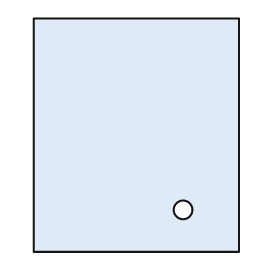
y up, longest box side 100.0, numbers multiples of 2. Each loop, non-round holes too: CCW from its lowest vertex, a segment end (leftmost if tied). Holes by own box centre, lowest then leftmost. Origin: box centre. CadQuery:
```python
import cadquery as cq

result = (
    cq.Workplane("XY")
    .moveTo(-44.0, -50.0)
    .lineTo(44.0, -50.0)
    .lineTo(44.0, 50.0)
    .lineTo(-44.0, 50.0)
    .close()
    .moveTo(20.0, -32.0)
    .circle(4.0)
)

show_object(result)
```